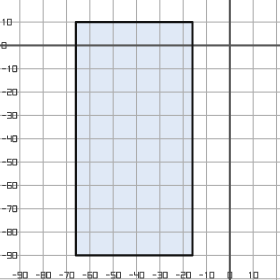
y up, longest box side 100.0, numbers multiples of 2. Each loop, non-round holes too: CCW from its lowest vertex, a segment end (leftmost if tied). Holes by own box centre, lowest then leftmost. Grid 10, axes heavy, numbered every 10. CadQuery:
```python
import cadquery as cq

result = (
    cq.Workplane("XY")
    .moveTo(-66.0, -90.0)
    .lineTo(-16.0, -90.0)
    .lineTo(-16.0, 10.0)
    .lineTo(-66.0, 10.0)
    .close()
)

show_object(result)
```